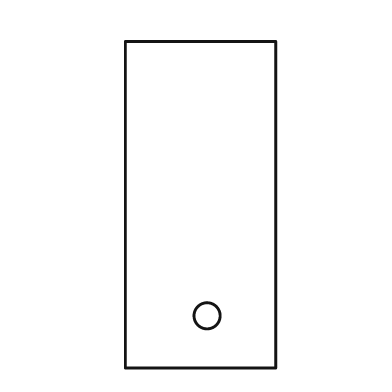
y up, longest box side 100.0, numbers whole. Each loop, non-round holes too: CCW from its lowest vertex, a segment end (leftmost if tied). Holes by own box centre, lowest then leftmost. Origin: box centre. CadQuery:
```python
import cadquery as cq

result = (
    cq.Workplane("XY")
    .moveTo(-23.0, -50.0)
    .lineTo(23.0, -50.0)
    .lineTo(23.0, 50.0)
    .lineTo(-23.0, 50.0)
    .close()
    .moveTo(2.0, -34.0)
    .circle(4.0)
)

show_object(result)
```